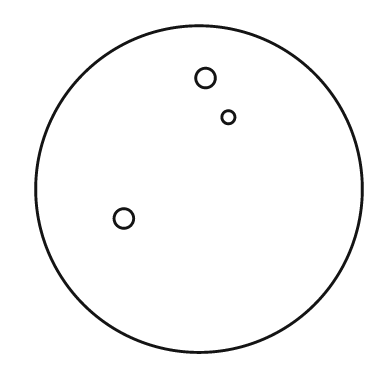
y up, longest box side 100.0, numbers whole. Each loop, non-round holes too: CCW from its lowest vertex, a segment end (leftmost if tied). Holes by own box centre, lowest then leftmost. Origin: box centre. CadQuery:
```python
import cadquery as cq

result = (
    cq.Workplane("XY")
    .moveTo(0.0, 0.0)
    .circle(50.0)
    .moveTo(-23.0, -9.0)
    .circle(3.0)
    .moveTo(9.0, 22.0)
    .circle(2.0)
    .moveTo(2.0, 34.0)
    .circle(3.0)
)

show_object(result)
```